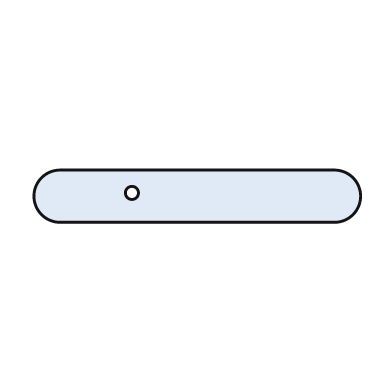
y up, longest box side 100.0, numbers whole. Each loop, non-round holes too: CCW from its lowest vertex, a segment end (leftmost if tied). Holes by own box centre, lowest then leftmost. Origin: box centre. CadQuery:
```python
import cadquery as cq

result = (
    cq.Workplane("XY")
    .moveTo(-42.0, -8.0)
    .lineTo(42.0, -8.0)
    .threePointArc((50.0, 0.0), (42.0, 8.0))
    .lineTo(-42.0, 8.0)
    .threePointArc((-50.0, 0.0), (-42.0, -8.0))
    .close()
    .moveTo(-20.0, 1.0)
    .circle(2.0)
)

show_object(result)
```